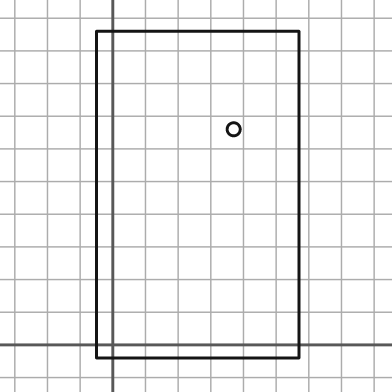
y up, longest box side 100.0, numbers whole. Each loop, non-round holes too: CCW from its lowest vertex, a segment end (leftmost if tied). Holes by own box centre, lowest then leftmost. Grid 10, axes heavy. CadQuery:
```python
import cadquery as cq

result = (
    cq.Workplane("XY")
    .moveTo(-5.0, -4.0)
    .lineTo(57.0, -4.0)
    .lineTo(57.0, 96.0)
    .lineTo(-5.0, 96.0)
    .close()
    .moveTo(37.0, 66.0)
    .circle(2.0)
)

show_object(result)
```